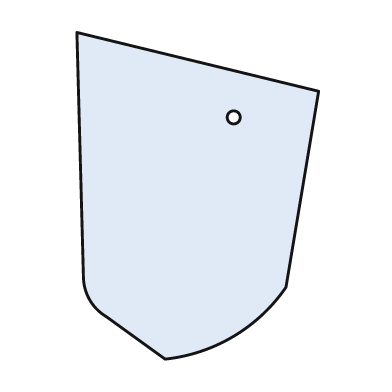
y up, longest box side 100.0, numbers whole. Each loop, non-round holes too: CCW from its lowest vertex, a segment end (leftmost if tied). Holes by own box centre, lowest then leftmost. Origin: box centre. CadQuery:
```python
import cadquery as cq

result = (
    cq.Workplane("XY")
    .moveTo(-10.0, -50.0)
    .threePointArc((11.0, -43.0), (27.0, -28.0))
    .lineTo(37.0, 32.0)
    .lineTo(-37.0, 50.0)
    .lineTo(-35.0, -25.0)
    .threePointArc((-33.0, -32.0), (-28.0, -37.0))
    .close()
    .moveTo(11.0, 24.0)
    .circle(2.0)
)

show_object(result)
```